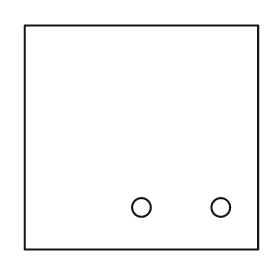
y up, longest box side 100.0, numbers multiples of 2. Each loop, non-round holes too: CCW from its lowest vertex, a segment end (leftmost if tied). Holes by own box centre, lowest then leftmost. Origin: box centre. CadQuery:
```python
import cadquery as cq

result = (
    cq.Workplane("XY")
    .moveTo(-50.0, -48.0)
    .lineTo(50.0, -48.0)
    .lineTo(50.0, 48.0)
    .lineTo(-50.0, 48.0)
    .close()
    .moveTo(0.0, -30.0)
    .circle(4.0)
    .moveTo(34.0, -30.0)
    .circle(4.0)
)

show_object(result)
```